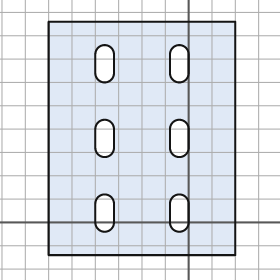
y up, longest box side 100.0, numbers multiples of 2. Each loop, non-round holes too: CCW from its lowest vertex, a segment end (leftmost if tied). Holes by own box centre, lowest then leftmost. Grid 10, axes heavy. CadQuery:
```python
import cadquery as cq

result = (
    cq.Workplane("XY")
    .moveTo(-60.0, -14.0)
    .lineTo(20.0, -14.0)
    .lineTo(20.0, 86.0)
    .lineTo(-60.0, 86.0)
    .close()
    .moveTo(-40.0, 0.0)
    .threePointArc((-36.0, -4.0), (-32.0, 0.0))
    .lineTo(-32.0, 8.0)
    .threePointArc((-36.0, 12.0), (-40.0, 8.0))
    .close()
    .moveTo(-8.0, 0.0)
    .threePointArc((-4.0, -4.0), (0.0, 0.0))
    .lineTo(0.0, 8.0)
    .threePointArc((-4.0, 12.0), (-8.0, 8.0))
    .close()
    .moveTo(-40.0, 32.0)
    .threePointArc((-36.0, 28.0), (-32.0, 32.0))
    .lineTo(-32.0, 40.0)
    .threePointArc((-36.0, 44.0), (-40.0, 40.0))
    .close()
    .moveTo(-8.0, 32.0)
    .threePointArc((-4.0, 28.0), (0.0, 32.0))
    .lineTo(0.0, 40.0)
    .threePointArc((-4.0, 44.0), (-8.0, 40.0))
    .close()
    .moveTo(-40.0, 64.0)
    .threePointArc((-36.0, 60.0), (-32.0, 64.0))
    .lineTo(-32.0, 72.0)
    .threePointArc((-36.0, 76.0), (-40.0, 72.0))
    .close()
    .moveTo(-8.0, 64.0)
    .threePointArc((-4.0, 60.0), (0.0, 64.0))
    .lineTo(0.0, 72.0)
    .threePointArc((-4.0, 76.0), (-8.0, 72.0))
    .close()
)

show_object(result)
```